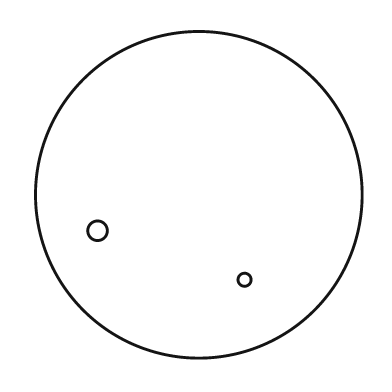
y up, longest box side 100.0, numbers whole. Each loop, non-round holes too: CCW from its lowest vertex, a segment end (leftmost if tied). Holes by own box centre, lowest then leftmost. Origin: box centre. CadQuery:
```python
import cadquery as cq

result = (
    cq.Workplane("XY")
    .moveTo(0.0, 0.0)
    .circle(50.0)
    .moveTo(14.0, -26.0)
    .circle(2.0)
    .moveTo(-31.0, -11.0)
    .circle(3.0)
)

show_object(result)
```